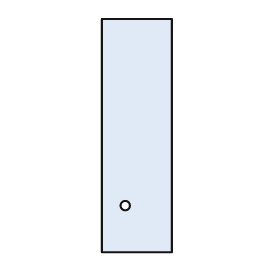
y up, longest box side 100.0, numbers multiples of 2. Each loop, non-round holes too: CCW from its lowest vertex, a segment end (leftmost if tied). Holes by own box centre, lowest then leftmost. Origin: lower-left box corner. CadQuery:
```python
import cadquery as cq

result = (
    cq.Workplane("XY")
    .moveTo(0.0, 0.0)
    .lineTo(30.0, 0.0)
    .lineTo(30.0, 100.0)
    .lineTo(0.0, 100.0)
    .close()
    .moveTo(10.0, 20.0)
    .circle(2.0)
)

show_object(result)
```